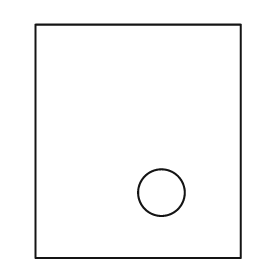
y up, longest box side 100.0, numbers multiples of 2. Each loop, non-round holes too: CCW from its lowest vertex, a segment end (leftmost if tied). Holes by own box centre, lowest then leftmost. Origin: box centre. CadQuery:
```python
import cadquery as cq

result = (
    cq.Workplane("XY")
    .moveTo(-44.0, -50.0)
    .lineTo(44.0, -50.0)
    .lineTo(44.0, 50.0)
    .lineTo(-44.0, 50.0)
    .close()
    .moveTo(10.0, -22.0)
    .circle(10.0)
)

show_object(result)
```